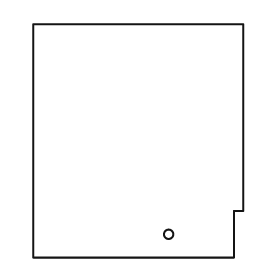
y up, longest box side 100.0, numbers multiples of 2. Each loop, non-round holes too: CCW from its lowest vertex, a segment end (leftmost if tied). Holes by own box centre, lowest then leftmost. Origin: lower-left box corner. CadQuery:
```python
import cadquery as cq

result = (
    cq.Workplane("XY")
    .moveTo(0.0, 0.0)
    .lineTo(86.0, 0.0)
    .lineTo(86.0, 20.0)
    .lineTo(90.0, 20.0)
    .lineTo(90.0, 100.0)
    .lineTo(0.0, 100.0)
    .close()
    .moveTo(58.0, 10.0)
    .circle(2.0)
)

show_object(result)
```